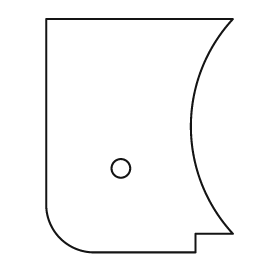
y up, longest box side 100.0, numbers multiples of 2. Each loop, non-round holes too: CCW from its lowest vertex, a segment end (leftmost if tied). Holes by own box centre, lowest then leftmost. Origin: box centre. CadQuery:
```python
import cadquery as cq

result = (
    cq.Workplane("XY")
    .moveTo(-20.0, -50.0)
    .lineTo(24.0, -50.0)
    .lineTo(24.0, -42.0)
    .lineTo(40.0, -42.0)
    .threePointArc((22.0, 4.0), (40.0, 50.0))
    .lineTo(-40.0, 50.0)
    .lineTo(-40.0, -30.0)
    .threePointArc((-34.0, -44.0), (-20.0, -50.0))
    .close()
    .moveTo(-8.0, -14.0)
    .circle(4.0)
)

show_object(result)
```